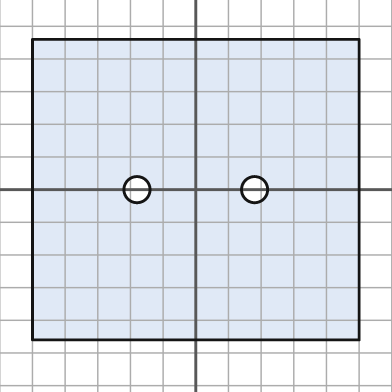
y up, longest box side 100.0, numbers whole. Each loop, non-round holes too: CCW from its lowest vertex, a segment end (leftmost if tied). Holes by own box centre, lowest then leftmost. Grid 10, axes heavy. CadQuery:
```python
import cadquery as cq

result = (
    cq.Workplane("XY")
    .moveTo(-50.0, -46.0)
    .lineTo(50.0, -46.0)
    .lineTo(50.0, 46.0)
    .lineTo(-50.0, 46.0)
    .close()
    .moveTo(-18.0, 0.0)
    .circle(4.0)
    .moveTo(18.0, 0.0)
    .circle(4.0)
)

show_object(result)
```